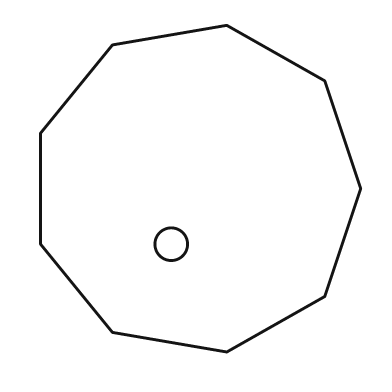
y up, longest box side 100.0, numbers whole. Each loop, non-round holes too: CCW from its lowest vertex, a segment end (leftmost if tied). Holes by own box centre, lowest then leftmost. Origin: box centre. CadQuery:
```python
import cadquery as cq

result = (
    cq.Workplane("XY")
    .moveTo(8.0, -50.0)
    .lineTo(38.0, -33.0)
    .lineTo(49.0, 0.0)
    .lineTo(38.0, 33.0)
    .lineTo(8.0, 50.0)
    .lineTo(-27.0, 44.0)
    .lineTo(-49.0, 17.0)
    .lineTo(-49.0, -17.0)
    .lineTo(-27.0, -44.0)
    .close()
    .moveTo(-9.0, -17.0)
    .circle(5.0)
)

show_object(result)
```